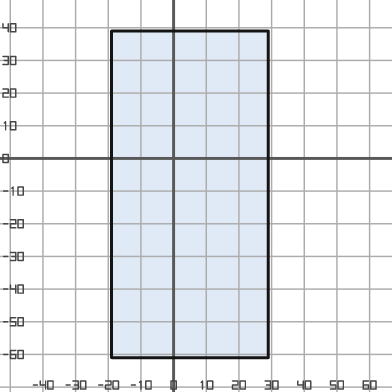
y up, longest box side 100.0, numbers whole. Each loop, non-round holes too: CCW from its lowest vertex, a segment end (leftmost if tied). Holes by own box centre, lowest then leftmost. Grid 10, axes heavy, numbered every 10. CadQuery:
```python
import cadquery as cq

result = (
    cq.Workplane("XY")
    .moveTo(-19.0, -61.0)
    .lineTo(29.0, -61.0)
    .lineTo(29.0, 39.0)
    .lineTo(-19.0, 39.0)
    .close()
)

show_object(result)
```